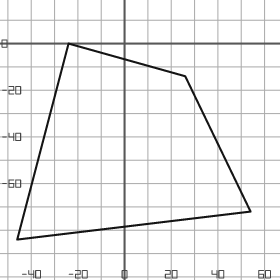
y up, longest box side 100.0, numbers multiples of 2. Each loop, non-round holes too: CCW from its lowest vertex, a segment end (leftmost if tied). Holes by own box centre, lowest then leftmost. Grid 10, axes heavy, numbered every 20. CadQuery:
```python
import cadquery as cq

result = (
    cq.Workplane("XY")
    .moveTo(-46.0, -84.0)
    .lineTo(54.0, -72.0)
    .lineTo(26.0, -14.0)
    .lineTo(-24.0, 0.0)
    .close()
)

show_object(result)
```